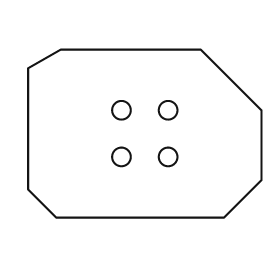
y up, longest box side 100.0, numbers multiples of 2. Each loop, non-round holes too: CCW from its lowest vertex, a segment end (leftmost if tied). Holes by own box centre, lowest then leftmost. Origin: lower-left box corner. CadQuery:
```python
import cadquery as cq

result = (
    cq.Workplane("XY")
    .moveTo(12.0, 0.0)
    .lineTo(84.0, 0.0)
    .lineTo(100.0, 16.0)
    .lineTo(100.0, 46.0)
    .lineTo(74.0, 72.0)
    .lineTo(14.0, 72.0)
    .lineTo(0.0, 64.0)
    .lineTo(0.0, 12.0)
    .close()
    .moveTo(40.0, 26.0)
    .circle(4.0)
    .moveTo(60.0, 26.0)
    .circle(4.0)
    .moveTo(40.0, 46.0)
    .circle(4.0)
    .moveTo(60.0, 46.0)
    .circle(4.0)
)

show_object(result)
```